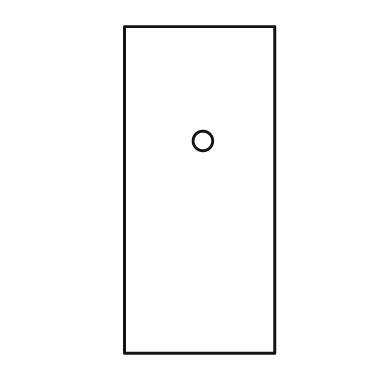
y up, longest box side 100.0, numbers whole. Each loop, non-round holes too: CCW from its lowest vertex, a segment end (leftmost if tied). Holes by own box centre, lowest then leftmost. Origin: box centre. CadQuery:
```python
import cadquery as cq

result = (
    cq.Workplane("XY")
    .moveTo(-23.0, -50.0)
    .lineTo(23.0, -50.0)
    .lineTo(23.0, 50.0)
    .lineTo(-23.0, 50.0)
    .close()
    .moveTo(1.0, 15.0)
    .circle(3.0)
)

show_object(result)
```